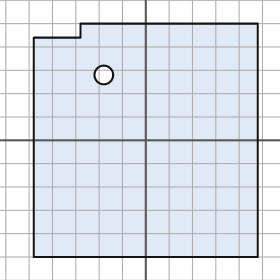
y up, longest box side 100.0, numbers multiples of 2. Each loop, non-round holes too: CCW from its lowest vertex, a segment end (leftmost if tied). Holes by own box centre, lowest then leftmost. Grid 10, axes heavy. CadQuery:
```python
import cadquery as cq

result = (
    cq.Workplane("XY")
    .moveTo(-48.0, -50.0)
    .lineTo(48.0, -50.0)
    .lineTo(48.0, 50.0)
    .lineTo(-28.0, 50.0)
    .lineTo(-28.0, 44.0)
    .lineTo(-48.0, 44.0)
    .close()
    .moveTo(-18.0, 28.0)
    .circle(4.0)
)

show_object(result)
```